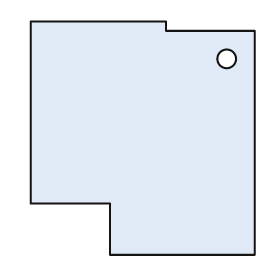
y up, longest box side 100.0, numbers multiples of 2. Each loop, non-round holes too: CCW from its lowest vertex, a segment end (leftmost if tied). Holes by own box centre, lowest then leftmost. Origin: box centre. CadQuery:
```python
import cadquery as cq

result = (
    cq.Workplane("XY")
    .moveTo(-14.0, -50.0)
    .lineTo(48.0, -50.0)
    .lineTo(48.0, 46.0)
    .lineTo(10.0, 46.0)
    .lineTo(10.0, 50.0)
    .lineTo(-48.0, 50.0)
    .lineTo(-48.0, -28.0)
    .lineTo(-14.0, -28.0)
    .close()
    .moveTo(36.0, 34.0)
    .circle(4.0)
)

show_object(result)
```